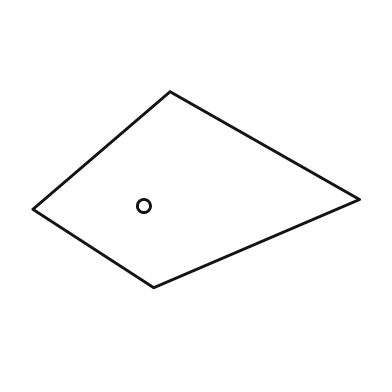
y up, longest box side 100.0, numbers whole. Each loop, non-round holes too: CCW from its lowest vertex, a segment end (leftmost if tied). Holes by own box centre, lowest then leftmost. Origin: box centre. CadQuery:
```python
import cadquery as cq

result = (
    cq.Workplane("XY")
    .moveTo(-13.0, -30.0)
    .lineTo(50.0, -3.0)
    .lineTo(-8.0, 30.0)
    .lineTo(-50.0, -6.0)
    .close()
    .moveTo(-16.0, -5.0)
    .circle(2.0)
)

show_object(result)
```